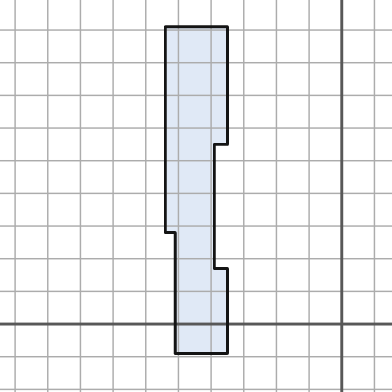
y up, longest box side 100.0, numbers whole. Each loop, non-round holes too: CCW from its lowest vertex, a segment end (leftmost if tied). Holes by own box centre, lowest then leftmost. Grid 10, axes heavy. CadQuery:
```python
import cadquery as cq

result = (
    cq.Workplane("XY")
    .moveTo(-51.0, -9.0)
    .lineTo(-35.0, -9.0)
    .lineTo(-35.0, 17.0)
    .lineTo(-39.0, 17.0)
    .lineTo(-39.0, 55.0)
    .lineTo(-35.0, 55.0)
    .lineTo(-35.0, 91.0)
    .lineTo(-54.0, 91.0)
    .lineTo(-54.0, 28.0)
    .lineTo(-51.0, 28.0)
    .close()
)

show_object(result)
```